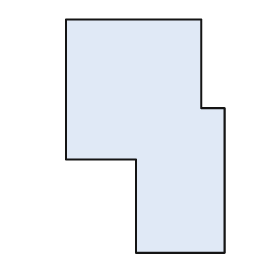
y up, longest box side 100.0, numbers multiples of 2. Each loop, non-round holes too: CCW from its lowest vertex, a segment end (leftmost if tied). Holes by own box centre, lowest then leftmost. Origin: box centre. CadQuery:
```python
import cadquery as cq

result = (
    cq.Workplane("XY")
    .moveTo(-4.0, -50.0)
    .lineTo(34.0, -50.0)
    .lineTo(34.0, 12.0)
    .lineTo(24.0, 12.0)
    .lineTo(24.0, 50.0)
    .lineTo(-34.0, 50.0)
    .lineTo(-34.0, -10.0)
    .lineTo(-4.0, -10.0)
    .close()
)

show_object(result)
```